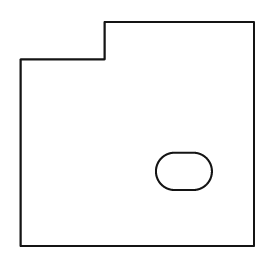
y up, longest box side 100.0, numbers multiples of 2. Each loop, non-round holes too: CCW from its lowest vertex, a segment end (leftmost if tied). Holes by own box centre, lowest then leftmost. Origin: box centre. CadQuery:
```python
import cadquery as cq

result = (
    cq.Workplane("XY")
    .moveTo(-50.0, -48.0)
    .lineTo(50.0, -48.0)
    .lineTo(50.0, 48.0)
    .lineTo(-14.0, 48.0)
    .lineTo(-14.0, 32.0)
    .lineTo(-50.0, 32.0)
    .close()
    .moveTo(16.0, -24.0)
    .lineTo(24.0, -24.0)
    .threePointArc((32.0, -16.0), (24.0, -8.0))
    .lineTo(16.0, -8.0)
    .threePointArc((8.0, -16.0), (16.0, -24.0))
    .close()
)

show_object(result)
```